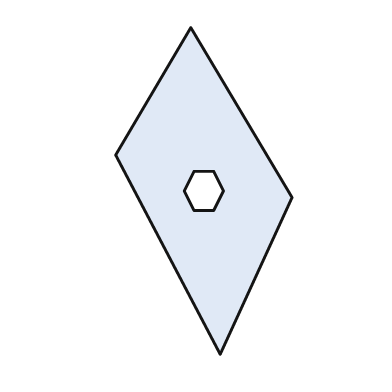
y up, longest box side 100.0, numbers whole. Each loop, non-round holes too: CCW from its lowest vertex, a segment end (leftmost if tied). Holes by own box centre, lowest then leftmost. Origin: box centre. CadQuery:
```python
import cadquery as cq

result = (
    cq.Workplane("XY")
    .moveTo(5.0, -50.0)
    .lineTo(27.0, -2.0)
    .lineTo(-4.0, 50.0)
    .lineTo(-27.0, 11.0)
    .close()
    .moveTo(-3.0, -6.0)
    .lineTo(3.0, -6.0)
    .lineTo(6.0, 0.0)
    .lineTo(3.0, 6.0)
    .lineTo(-3.0, 6.0)
    .lineTo(-6.0, 0.0)
    .close()
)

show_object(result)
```